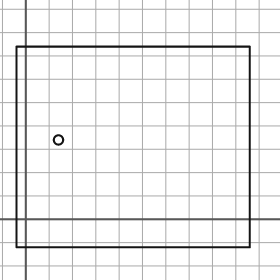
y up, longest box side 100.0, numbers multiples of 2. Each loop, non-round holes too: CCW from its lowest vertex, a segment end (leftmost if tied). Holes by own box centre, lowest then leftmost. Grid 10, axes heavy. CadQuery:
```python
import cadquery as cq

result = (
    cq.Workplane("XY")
    .moveTo(-4.0, -12.0)
    .lineTo(96.0, -12.0)
    .lineTo(96.0, 74.0)
    .lineTo(-4.0, 74.0)
    .close()
    .moveTo(14.0, 34.0)
    .circle(2.0)
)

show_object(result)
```